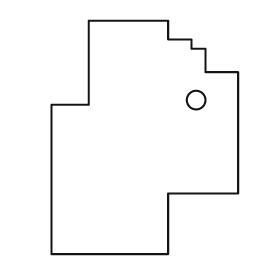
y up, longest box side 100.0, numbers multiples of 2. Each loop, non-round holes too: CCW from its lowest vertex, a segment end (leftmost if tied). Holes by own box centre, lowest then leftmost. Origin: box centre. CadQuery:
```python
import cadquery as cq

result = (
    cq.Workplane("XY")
    .moveTo(-40.0, -50.0)
    .lineTo(10.0, -50.0)
    .lineTo(10.0, -24.0)
    .lineTo(40.0, -24.0)
    .lineTo(40.0, 28.0)
    .lineTo(26.0, 28.0)
    .lineTo(26.0, 38.0)
    .lineTo(20.0, 38.0)
    .lineTo(20.0, 42.0)
    .lineTo(10.0, 42.0)
    .lineTo(10.0, 50.0)
    .lineTo(-24.0, 50.0)
    .lineTo(-24.0, 14.0)
    .lineTo(-40.0, 14.0)
    .close()
    .moveTo(22.0, 16.0)
    .circle(4.0)
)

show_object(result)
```